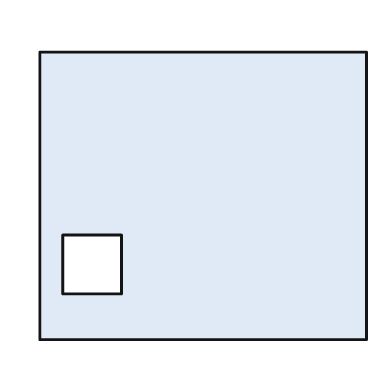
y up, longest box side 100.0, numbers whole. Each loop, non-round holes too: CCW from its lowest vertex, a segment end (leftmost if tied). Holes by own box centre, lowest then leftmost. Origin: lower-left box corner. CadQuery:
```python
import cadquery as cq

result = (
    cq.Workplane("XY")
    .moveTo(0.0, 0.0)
    .lineTo(100.0, 0.0)
    .lineTo(100.0, 88.0)
    .lineTo(0.0, 88.0)
    .close()
    .moveTo(7.0, 14.0)
    .lineTo(25.0, 14.0)
    .lineTo(25.0, 32.0)
    .lineTo(7.0, 32.0)
    .close()
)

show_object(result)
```